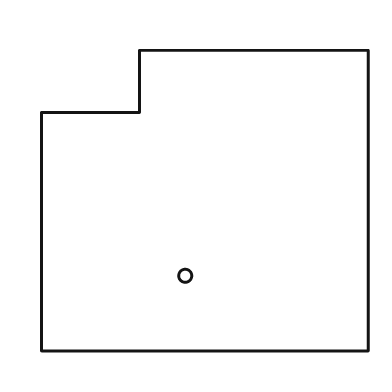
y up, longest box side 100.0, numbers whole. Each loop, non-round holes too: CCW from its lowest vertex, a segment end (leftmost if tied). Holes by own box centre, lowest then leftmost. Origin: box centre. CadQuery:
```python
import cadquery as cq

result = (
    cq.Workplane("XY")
    .moveTo(-50.0, -46.0)
    .lineTo(50.0, -46.0)
    .lineTo(50.0, 46.0)
    .lineTo(-20.0, 46.0)
    .lineTo(-20.0, 27.0)
    .lineTo(-50.0, 27.0)
    .close()
    .moveTo(-6.0, -23.0)
    .circle(2.0)
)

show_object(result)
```